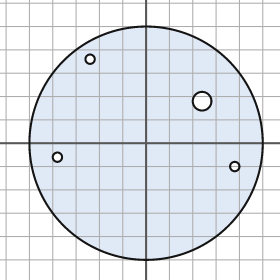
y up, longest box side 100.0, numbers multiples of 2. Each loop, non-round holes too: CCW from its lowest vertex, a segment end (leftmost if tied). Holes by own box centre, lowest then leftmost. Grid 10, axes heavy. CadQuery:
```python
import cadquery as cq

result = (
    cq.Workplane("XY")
    .moveTo(0.0, 0.0)
    .circle(50.0)
    .moveTo(38.0, -10.0)
    .circle(2.0)
    .moveTo(-38.0, -6.0)
    .circle(2.0)
    .moveTo(24.0, 18.0)
    .circle(4.0)
    .moveTo(-24.0, 36.0)
    .circle(2.0)
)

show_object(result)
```